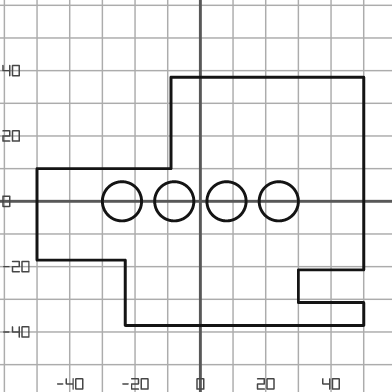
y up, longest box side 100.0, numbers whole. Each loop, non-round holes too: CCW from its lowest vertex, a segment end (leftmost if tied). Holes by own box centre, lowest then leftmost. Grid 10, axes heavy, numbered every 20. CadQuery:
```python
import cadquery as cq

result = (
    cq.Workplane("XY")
    .moveTo(-23.0, -38.0)
    .lineTo(50.0, -38.0)
    .lineTo(50.0, -31.0)
    .lineTo(30.0, -31.0)
    .lineTo(30.0, -21.0)
    .lineTo(50.0, -21.0)
    .lineTo(50.0, 38.0)
    .lineTo(-9.0, 38.0)
    .lineTo(-9.0, 10.0)
    .lineTo(-50.0, 10.0)
    .lineTo(-50.0, -18.0)
    .lineTo(-23.0, -18.0)
    .close()
    .moveTo(-24.0, 0.0)
    .circle(6.0)
    .moveTo(-8.0, 0.0)
    .circle(6.0)
    .moveTo(8.0, 0.0)
    .circle(6.0)
    .moveTo(24.0, 0.0)
    .circle(6.0)
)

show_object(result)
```